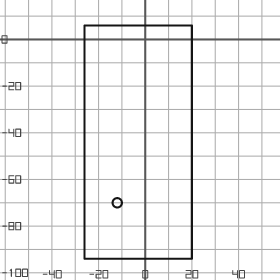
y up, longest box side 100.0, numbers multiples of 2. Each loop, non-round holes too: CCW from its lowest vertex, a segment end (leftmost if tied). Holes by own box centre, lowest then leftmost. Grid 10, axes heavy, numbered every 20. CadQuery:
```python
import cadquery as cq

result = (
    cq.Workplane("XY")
    .moveTo(-26.0, -94.0)
    .lineTo(20.0, -94.0)
    .lineTo(20.0, 6.0)
    .lineTo(-26.0, 6.0)
    .close()
    .moveTo(-12.0, -70.0)
    .circle(2.0)
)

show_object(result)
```